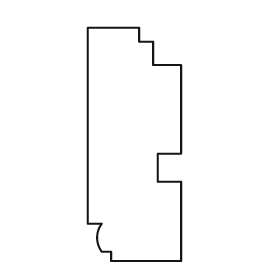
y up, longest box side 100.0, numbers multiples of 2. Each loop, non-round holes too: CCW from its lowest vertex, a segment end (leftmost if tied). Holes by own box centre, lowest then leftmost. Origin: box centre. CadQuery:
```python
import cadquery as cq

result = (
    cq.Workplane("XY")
    .moveTo(-10.0, -50.0)
    .lineTo(20.0, -50.0)
    .lineTo(20.0, -16.0)
    .lineTo(10.0, -16.0)
    .lineTo(10.0, -4.0)
    .lineTo(20.0, -4.0)
    .lineTo(20.0, 34.0)
    .lineTo(8.0, 34.0)
    .lineTo(8.0, 44.0)
    .lineTo(2.0, 44.0)
    .lineTo(2.0, 50.0)
    .lineTo(-20.0, 50.0)
    .lineTo(-20.0, -34.0)
    .lineTo(-14.0, -34.0)
    .threePointArc((-16.0, -40.0), (-14.0, -46.0))
    .lineTo(-10.0, -46.0)
    .close()
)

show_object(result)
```